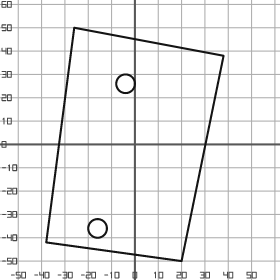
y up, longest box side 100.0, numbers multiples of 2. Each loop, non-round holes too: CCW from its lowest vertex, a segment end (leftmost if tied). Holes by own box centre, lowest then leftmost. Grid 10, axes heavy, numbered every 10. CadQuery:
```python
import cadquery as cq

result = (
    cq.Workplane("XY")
    .moveTo(20.0, -50.0)
    .lineTo(38.0, 38.0)
    .lineTo(-26.0, 50.0)
    .lineTo(-38.0, -42.0)
    .close()
    .moveTo(-16.0, -36.0)
    .circle(4.0)
    .moveTo(-4.0, 26.0)
    .circle(4.0)
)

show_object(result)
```